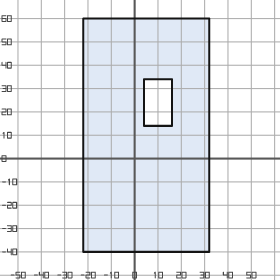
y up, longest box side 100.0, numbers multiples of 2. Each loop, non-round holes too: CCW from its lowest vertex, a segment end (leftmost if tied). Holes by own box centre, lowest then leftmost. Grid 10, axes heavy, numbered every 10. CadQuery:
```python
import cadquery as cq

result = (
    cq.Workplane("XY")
    .moveTo(-22.0, -40.0)
    .lineTo(32.0, -40.0)
    .lineTo(32.0, 60.0)
    .lineTo(-22.0, 60.0)
    .close()
    .moveTo(4.0, 14.0)
    .lineTo(16.0, 14.0)
    .lineTo(16.0, 34.0)
    .lineTo(4.0, 34.0)
    .close()
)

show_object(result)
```